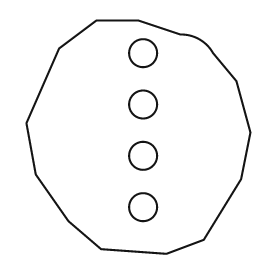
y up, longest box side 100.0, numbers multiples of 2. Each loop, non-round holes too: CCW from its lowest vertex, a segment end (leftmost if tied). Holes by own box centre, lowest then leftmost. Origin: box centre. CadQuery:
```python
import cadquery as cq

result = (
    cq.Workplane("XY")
    .moveTo(12.0, -50.0)
    .lineTo(28.0, -44.0)
    .lineTo(44.0, -18.0)
    .lineTo(48.0, 2.0)
    .lineTo(42.0, 24.0)
    .lineTo(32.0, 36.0)
    .threePointArc((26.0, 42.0), (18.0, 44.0))
    .lineTo(0.0, 50.0)
    .lineTo(-18.0, 50.0)
    .lineTo(-34.0, 38.0)
    .lineTo(-48.0, 6.0)
    .lineTo(-44.0, -16.0)
    .lineTo(-30.0, -36.0)
    .lineTo(-16.0, -48.0)
    .close()
    .moveTo(2.0, -30.0)
    .circle(6.0)
    .moveTo(2.0, -8.0)
    .circle(6.0)
    .moveTo(2.0, 14.0)
    .circle(6.0)
    .moveTo(2.0, 36.0)
    .circle(6.0)
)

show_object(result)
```